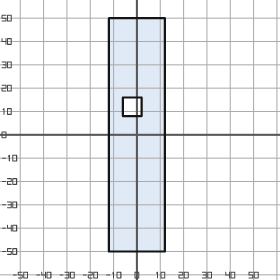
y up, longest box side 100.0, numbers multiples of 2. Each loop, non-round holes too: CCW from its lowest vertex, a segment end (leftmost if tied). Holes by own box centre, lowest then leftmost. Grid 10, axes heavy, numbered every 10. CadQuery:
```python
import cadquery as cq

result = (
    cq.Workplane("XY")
    .moveTo(-12.0, -50.0)
    .lineTo(12.0, -50.0)
    .lineTo(12.0, 50.0)
    .lineTo(-12.0, 50.0)
    .close()
    .moveTo(-6.0, 8.0)
    .lineTo(2.0, 8.0)
    .lineTo(2.0, 16.0)
    .lineTo(-6.0, 16.0)
    .close()
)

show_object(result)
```